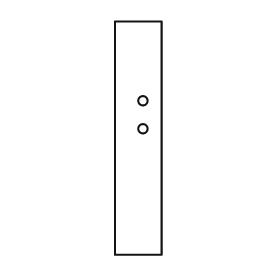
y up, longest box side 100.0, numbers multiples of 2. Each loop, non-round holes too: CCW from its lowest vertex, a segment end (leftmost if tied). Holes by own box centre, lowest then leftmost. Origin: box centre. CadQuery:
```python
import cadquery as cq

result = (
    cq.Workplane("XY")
    .moveTo(-10.0, -50.0)
    .lineTo(10.0, -50.0)
    .lineTo(10.0, 50.0)
    .lineTo(-10.0, 50.0)
    .close()
    .moveTo(2.0, 4.0)
    .circle(2.0)
    .moveTo(2.0, 16.0)
    .circle(2.0)
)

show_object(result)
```